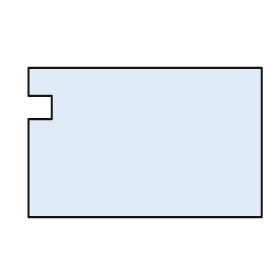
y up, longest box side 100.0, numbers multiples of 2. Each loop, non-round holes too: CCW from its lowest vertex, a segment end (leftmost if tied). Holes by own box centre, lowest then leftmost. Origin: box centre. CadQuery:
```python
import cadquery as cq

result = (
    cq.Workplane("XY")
    .moveTo(-50.0, -32.0)
    .lineTo(50.0, -32.0)
    .lineTo(50.0, 32.0)
    .lineTo(-50.0, 32.0)
    .lineTo(-50.0, 20.0)
    .lineTo(-40.0, 20.0)
    .lineTo(-40.0, 10.0)
    .lineTo(-50.0, 10.0)
    .close()
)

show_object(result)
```